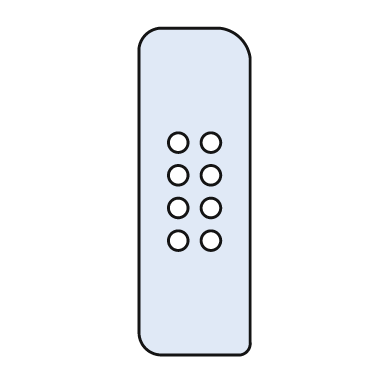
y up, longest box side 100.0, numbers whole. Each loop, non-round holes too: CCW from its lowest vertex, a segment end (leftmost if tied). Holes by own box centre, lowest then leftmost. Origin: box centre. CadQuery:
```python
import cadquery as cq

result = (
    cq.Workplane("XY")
    .moveTo(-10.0, -50.0)
    .lineTo(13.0, -50.0)
    .threePointArc((16.0, -49.0), (17.0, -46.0))
    .lineTo(17.0, 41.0)
    .threePointArc((14.0, 47.0), (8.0, 50.0))
    .lineTo(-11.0, 50.0)
    .threePointArc((-15.0, 48.0), (-17.0, 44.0))
    .lineTo(-17.0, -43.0)
    .threePointArc((-15.0, -48.0), (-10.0, -50.0))
    .close()
    .moveTo(-5.0, -15.0)
    .circle(3.0)
    .moveTo(5.0, -15.0)
    .circle(3.0)
    .moveTo(-5.0, -5.0)
    .circle(3.0)
    .moveTo(5.0, -5.0)
    .circle(3.0)
    .moveTo(-5.0, 5.0)
    .circle(3.0)
    .moveTo(5.0, 5.0)
    .circle(3.0)
    .moveTo(-5.0, 15.0)
    .circle(3.0)
    .moveTo(5.0, 15.0)
    .circle(3.0)
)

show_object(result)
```